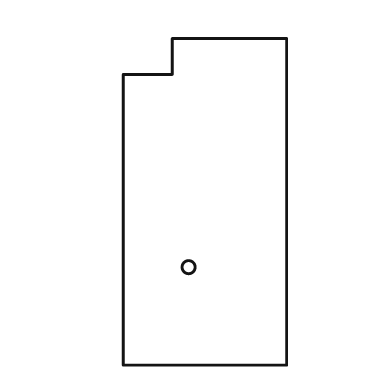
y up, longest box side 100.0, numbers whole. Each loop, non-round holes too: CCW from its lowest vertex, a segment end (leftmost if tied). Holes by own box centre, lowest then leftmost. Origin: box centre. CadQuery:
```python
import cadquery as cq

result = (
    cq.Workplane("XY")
    .moveTo(-25.0, -50.0)
    .lineTo(25.0, -50.0)
    .lineTo(25.0, 50.0)
    .lineTo(-10.0, 50.0)
    .lineTo(-10.0, 39.0)
    .lineTo(-25.0, 39.0)
    .close()
    .moveTo(-5.0, -20.0)
    .circle(2.0)
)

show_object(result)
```